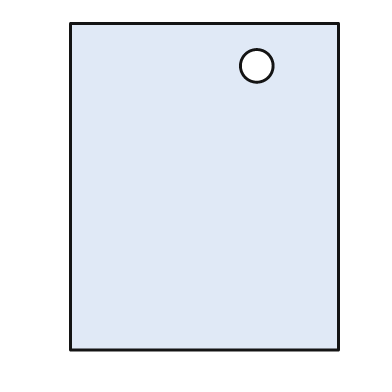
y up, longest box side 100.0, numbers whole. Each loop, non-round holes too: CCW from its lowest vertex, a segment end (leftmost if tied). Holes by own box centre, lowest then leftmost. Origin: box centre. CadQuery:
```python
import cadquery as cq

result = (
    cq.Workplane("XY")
    .moveTo(-41.0, -50.0)
    .lineTo(41.0, -50.0)
    .lineTo(41.0, 50.0)
    .lineTo(-41.0, 50.0)
    .close()
    .moveTo(16.0, 37.0)
    .circle(5.0)
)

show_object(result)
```